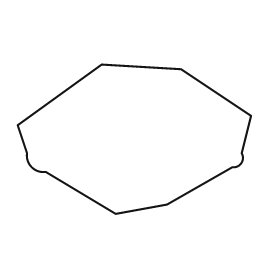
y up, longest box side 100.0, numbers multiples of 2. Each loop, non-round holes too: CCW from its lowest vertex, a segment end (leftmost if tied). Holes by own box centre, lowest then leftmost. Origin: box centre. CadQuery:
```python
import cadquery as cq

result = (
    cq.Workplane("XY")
    .moveTo(-8.0, -32.0)
    .lineTo(14.0, -28.0)
    .lineTo(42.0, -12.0)
    .threePointArc((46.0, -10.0), (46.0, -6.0))
    .lineTo(50.0, 10.0)
    .lineTo(20.0, 30.0)
    .lineTo(-14.0, 32.0)
    .lineTo(-50.0, 6.0)
    .lineTo(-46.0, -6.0)
    .threePointArc((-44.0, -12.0), (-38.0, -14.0))
    .close()
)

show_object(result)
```